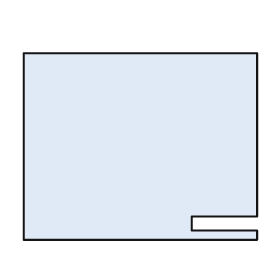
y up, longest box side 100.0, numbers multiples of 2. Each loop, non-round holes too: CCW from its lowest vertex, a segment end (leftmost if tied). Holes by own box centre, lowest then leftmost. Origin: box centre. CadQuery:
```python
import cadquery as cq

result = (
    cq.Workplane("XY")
    .moveTo(-50.0, -40.0)
    .lineTo(50.0, -40.0)
    .lineTo(50.0, -36.0)
    .lineTo(22.0, -36.0)
    .lineTo(22.0, -30.0)
    .lineTo(50.0, -30.0)
    .lineTo(50.0, 40.0)
    .lineTo(-50.0, 40.0)
    .close()
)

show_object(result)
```